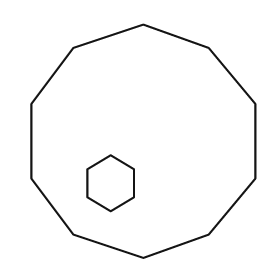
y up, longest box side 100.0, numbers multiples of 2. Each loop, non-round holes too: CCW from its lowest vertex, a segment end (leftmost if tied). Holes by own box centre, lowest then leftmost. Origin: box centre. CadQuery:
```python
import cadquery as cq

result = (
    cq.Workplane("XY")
    .moveTo(0.0, -50.0)
    .lineTo(28.0, -40.0)
    .lineTo(48.0, -16.0)
    .lineTo(48.0, 16.0)
    .lineTo(28.0, 40.0)
    .lineTo(0.0, 50.0)
    .lineTo(-30.0, 40.0)
    .lineTo(-48.0, 16.0)
    .lineTo(-48.0, -16.0)
    .lineTo(-30.0, -40.0)
    .close()
    .moveTo(-14.0, -30.0)
    .lineTo(-4.0, -24.0)
    .lineTo(-4.0, -12.0)
    .lineTo(-14.0, -6.0)
    .lineTo(-24.0, -12.0)
    .lineTo(-24.0, -24.0)
    .close()
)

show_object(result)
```